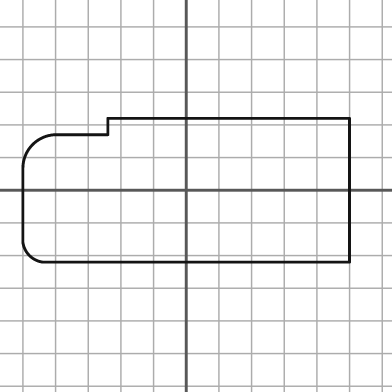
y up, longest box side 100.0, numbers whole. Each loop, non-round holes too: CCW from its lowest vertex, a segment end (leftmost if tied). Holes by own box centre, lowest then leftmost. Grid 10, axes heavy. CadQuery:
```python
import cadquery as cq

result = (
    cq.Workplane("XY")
    .moveTo(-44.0, -22.0)
    .lineTo(50.0, -22.0)
    .lineTo(50.0, 22.0)
    .lineTo(-24.0, 22.0)
    .lineTo(-24.0, 17.0)
    .lineTo(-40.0, 17.0)
    .threePointArc((-47.0, 14.0), (-50.0, 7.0))
    .lineTo(-50.0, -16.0)
    .threePointArc((-48.0, -20.0), (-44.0, -22.0))
    .close()
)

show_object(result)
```